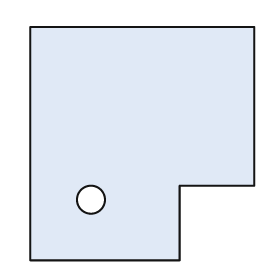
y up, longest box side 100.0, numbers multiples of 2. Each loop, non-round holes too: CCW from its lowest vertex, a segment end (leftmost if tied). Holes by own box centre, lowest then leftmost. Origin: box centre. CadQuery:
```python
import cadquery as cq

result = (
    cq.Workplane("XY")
    .moveTo(-48.0, -50.0)
    .lineTo(16.0, -50.0)
    .lineTo(16.0, -18.0)
    .lineTo(48.0, -18.0)
    .lineTo(48.0, 50.0)
    .lineTo(-48.0, 50.0)
    .close()
    .moveTo(-22.0, -24.0)
    .circle(6.0)
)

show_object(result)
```